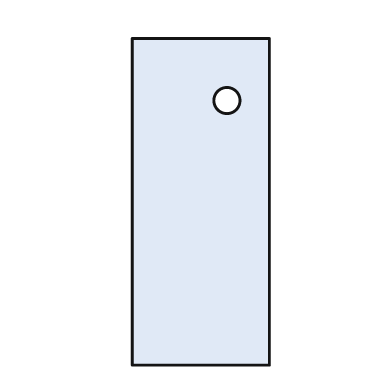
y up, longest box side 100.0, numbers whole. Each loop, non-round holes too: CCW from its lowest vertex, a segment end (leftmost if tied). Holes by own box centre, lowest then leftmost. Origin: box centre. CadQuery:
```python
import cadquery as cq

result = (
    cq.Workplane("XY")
    .moveTo(-21.0, -50.0)
    .lineTo(21.0, -50.0)
    .lineTo(21.0, 50.0)
    .lineTo(-21.0, 50.0)
    .close()
    .moveTo(8.0, 31.0)
    .circle(4.0)
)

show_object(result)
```